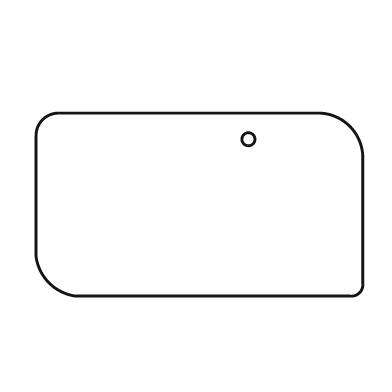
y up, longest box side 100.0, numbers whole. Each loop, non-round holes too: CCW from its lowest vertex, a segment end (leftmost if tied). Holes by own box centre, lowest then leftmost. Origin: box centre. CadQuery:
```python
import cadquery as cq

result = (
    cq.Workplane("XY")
    .moveTo(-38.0, -28.0)
    .lineTo(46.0, -28.0)
    .threePointArc((49.0, -27.0), (50.0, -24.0))
    .lineTo(50.0, 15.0)
    .threePointArc((46.0, 24.0), (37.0, 28.0))
    .lineTo(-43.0, 28.0)
    .threePointArc((-48.0, 26.0), (-50.0, 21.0))
    .lineTo(-50.0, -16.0)
    .threePointArc((-46.0, -24.0), (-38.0, -28.0))
    .close()
    .moveTo(15.0, 20.0)
    .circle(2.0)
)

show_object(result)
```